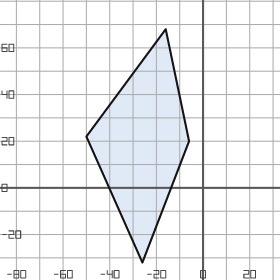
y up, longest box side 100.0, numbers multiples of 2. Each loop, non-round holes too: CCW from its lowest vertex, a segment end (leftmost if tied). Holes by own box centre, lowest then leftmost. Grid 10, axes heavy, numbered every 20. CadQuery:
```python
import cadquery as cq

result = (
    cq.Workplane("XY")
    .moveTo(-26.0, -32.0)
    .lineTo(-6.0, 20.0)
    .lineTo(-16.0, 68.0)
    .lineTo(-50.0, 22.0)
    .close()
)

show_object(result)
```